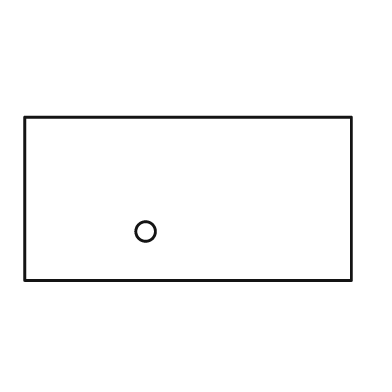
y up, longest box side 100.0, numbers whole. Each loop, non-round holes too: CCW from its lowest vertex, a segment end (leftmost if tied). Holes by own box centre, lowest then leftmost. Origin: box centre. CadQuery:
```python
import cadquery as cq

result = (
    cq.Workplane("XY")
    .moveTo(-50.0, -25.0)
    .lineTo(50.0, -25.0)
    .lineTo(50.0, 25.0)
    .lineTo(-50.0, 25.0)
    .close()
    .moveTo(-13.0, -10.0)
    .circle(3.0)
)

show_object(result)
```